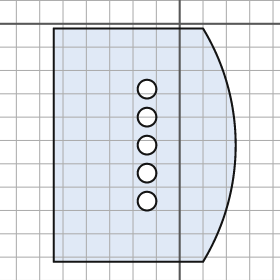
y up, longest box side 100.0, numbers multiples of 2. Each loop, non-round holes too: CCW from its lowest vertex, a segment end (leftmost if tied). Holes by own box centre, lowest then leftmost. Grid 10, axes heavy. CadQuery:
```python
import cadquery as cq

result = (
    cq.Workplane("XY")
    .moveTo(-54.0, -102.0)
    .lineTo(10.0, -102.0)
    .threePointArc((24.0, -52.0), (10.0, -2.0))
    .lineTo(-54.0, -2.0)
    .close()
    .moveTo(-14.0, -76.0)
    .circle(4.0)
    .moveTo(-14.0, -64.0)
    .circle(4.0)
    .moveTo(-14.0, -52.0)
    .circle(4.0)
    .moveTo(-14.0, -40.0)
    .circle(4.0)
    .moveTo(-14.0, -28.0)
    .circle(4.0)
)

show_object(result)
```